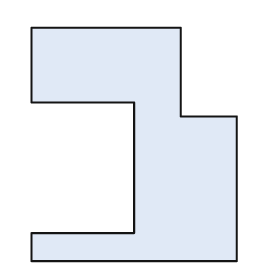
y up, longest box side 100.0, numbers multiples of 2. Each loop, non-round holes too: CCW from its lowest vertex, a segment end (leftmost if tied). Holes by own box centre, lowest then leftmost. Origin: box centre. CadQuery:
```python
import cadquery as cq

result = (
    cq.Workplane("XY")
    .moveTo(-44.0, -50.0)
    .lineTo(44.0, -50.0)
    .lineTo(44.0, 12.0)
    .lineTo(20.0, 12.0)
    .lineTo(20.0, 50.0)
    .lineTo(-44.0, 50.0)
    .lineTo(-44.0, 18.0)
    .lineTo(0.0, 18.0)
    .lineTo(0.0, -38.0)
    .lineTo(-44.0, -38.0)
    .close()
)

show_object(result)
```